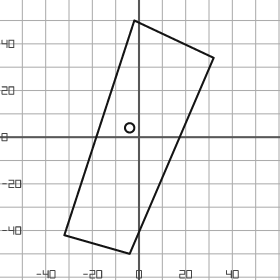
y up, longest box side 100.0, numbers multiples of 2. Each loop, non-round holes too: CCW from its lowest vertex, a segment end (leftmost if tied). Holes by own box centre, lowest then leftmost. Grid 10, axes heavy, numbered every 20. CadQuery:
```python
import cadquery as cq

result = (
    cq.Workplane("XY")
    .moveTo(-4.0, -50.0)
    .lineTo(32.0, 34.0)
    .lineTo(-2.0, 50.0)
    .lineTo(-32.0, -42.0)
    .close()
    .moveTo(-4.0, 4.0)
    .circle(2.0)
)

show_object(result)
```